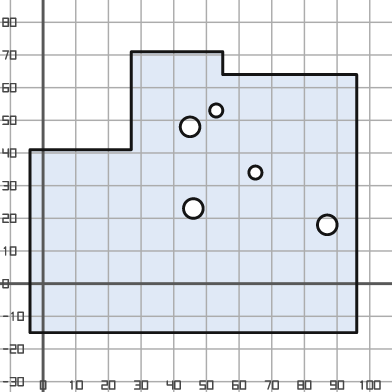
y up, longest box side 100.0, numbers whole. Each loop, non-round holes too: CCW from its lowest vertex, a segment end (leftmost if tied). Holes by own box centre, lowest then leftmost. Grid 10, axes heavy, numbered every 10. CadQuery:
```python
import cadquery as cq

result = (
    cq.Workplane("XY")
    .moveTo(-4.0, -15.0)
    .lineTo(96.0, -15.0)
    .lineTo(96.0, 64.0)
    .lineTo(55.0, 64.0)
    .lineTo(55.0, 71.0)
    .lineTo(27.0, 71.0)
    .lineTo(27.0, 41.0)
    .lineTo(-4.0, 41.0)
    .close()
    .moveTo(87.0, 18.0)
    .circle(3.0)
    .moveTo(46.0, 23.0)
    .circle(3.0)
    .moveTo(65.0, 34.0)
    .circle(2.0)
    .moveTo(45.0, 48.0)
    .circle(3.0)
    .moveTo(53.0, 53.0)
    .circle(2.0)
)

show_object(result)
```